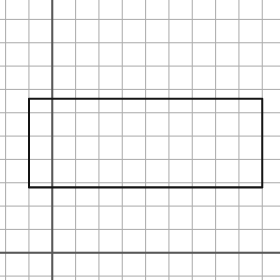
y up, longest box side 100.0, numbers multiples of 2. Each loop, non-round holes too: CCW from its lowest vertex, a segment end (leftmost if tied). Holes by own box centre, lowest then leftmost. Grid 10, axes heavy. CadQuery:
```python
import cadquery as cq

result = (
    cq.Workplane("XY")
    .moveTo(-10.0, 28.0)
    .lineTo(90.0, 28.0)
    .lineTo(90.0, 66.0)
    .lineTo(-10.0, 66.0)
    .close()
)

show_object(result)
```